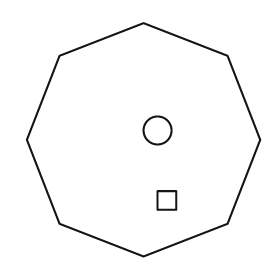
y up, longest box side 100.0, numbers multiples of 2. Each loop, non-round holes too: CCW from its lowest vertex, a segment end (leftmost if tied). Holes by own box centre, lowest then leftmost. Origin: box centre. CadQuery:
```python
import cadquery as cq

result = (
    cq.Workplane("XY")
    .moveTo(0.0, -50.0)
    .lineTo(36.0, -36.0)
    .lineTo(50.0, 0.0)
    .lineTo(36.0, 36.0)
    .lineTo(0.0, 50.0)
    .lineTo(-36.0, 36.0)
    .lineTo(-50.0, 0.0)
    .lineTo(-36.0, -36.0)
    .close()
    .moveTo(6.0, -30.0)
    .lineTo(14.0, -30.0)
    .lineTo(14.0, -22.0)
    .lineTo(6.0, -22.0)
    .close()
    .moveTo(6.0, 4.0)
    .circle(6.0)
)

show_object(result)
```